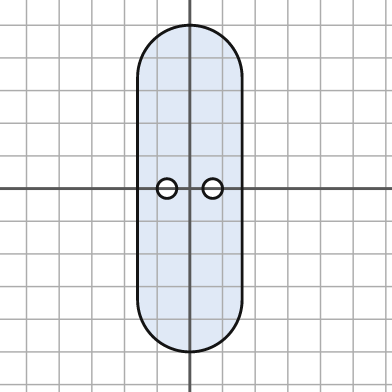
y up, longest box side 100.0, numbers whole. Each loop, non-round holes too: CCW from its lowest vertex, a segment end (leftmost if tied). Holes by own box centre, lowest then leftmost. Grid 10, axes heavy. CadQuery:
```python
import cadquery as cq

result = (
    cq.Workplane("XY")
    .moveTo(-16.0, -34.0)
    .threePointArc((0.0, -50.0), (16.0, -34.0))
    .lineTo(16.0, 34.0)
    .threePointArc((0.0, 50.0), (-16.0, 34.0))
    .close()
    .moveTo(-7.0, 0.0)
    .circle(3.0)
    .moveTo(7.0, 0.0)
    .circle(3.0)
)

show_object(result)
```